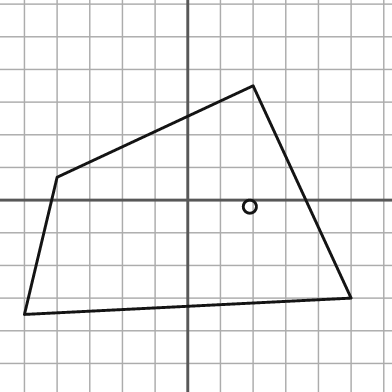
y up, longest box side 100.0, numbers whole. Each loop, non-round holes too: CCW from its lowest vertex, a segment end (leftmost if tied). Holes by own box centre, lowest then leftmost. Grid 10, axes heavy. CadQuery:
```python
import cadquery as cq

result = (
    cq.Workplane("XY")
    .moveTo(-50.0, -35.0)
    .lineTo(50.0, -30.0)
    .lineTo(20.0, 35.0)
    .lineTo(-40.0, 7.0)
    .close()
    .moveTo(19.0, -2.0)
    .circle(2.0)
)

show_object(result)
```